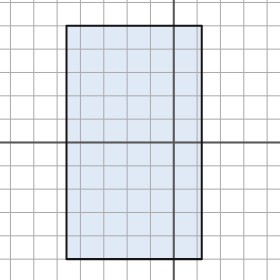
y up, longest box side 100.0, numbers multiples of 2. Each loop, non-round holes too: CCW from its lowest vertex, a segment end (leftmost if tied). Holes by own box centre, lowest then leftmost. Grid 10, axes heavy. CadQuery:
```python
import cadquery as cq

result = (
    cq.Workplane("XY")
    .moveTo(-46.0, -50.0)
    .lineTo(12.0, -50.0)
    .lineTo(12.0, 50.0)
    .lineTo(-46.0, 50.0)
    .close()
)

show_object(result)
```